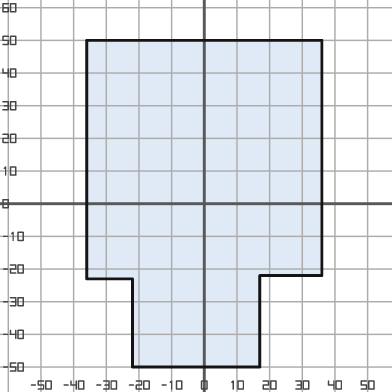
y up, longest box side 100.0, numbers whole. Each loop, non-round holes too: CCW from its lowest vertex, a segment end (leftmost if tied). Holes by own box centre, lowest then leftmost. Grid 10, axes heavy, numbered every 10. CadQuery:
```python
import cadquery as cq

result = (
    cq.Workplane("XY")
    .moveTo(-22.0, -50.0)
    .lineTo(17.0, -50.0)
    .lineTo(17.0, -22.0)
    .lineTo(36.0, -22.0)
    .lineTo(36.0, 50.0)
    .lineTo(-36.0, 50.0)
    .lineTo(-36.0, -23.0)
    .lineTo(-22.0, -23.0)
    .close()
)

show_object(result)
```